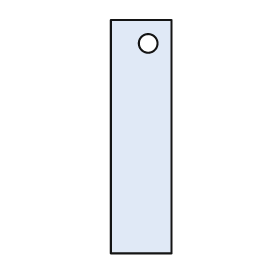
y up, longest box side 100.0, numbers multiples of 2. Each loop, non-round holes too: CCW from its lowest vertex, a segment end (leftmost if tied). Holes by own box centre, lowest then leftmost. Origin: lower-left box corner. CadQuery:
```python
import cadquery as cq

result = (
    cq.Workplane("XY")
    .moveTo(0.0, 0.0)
    .lineTo(26.0, 0.0)
    .lineTo(26.0, 100.0)
    .lineTo(0.0, 100.0)
    .close()
    .moveTo(16.0, 90.0)
    .circle(4.0)
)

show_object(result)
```